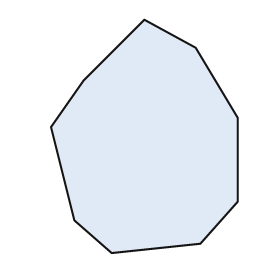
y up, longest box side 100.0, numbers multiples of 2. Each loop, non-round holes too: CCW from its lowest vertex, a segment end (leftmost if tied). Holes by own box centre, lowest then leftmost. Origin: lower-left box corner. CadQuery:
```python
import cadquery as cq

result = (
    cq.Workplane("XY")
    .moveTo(26.0, 0.0)
    .lineTo(64.0, 4.0)
    .lineTo(80.0, 22.0)
    .lineTo(80.0, 58.0)
    .lineTo(62.0, 88.0)
    .lineTo(40.0, 100.0)
    .lineTo(14.0, 74.0)
    .lineTo(0.0, 54.0)
    .lineTo(10.0, 14.0)
    .close()
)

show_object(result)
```